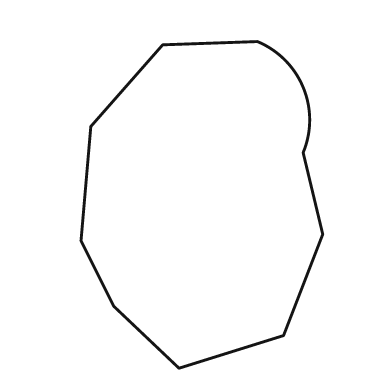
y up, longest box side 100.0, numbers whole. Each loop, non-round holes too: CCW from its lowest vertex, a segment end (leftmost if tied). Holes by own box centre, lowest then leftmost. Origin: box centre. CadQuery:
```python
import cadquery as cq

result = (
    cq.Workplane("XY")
    .moveTo(-7.0, -50.0)
    .lineTo(25.0, -40.0)
    .lineTo(37.0, -9.0)
    .lineTo(31.0, 16.0)
    .threePointArc((31.0, 36.0), (17.0, 50.0))
    .lineTo(-12.0, 49.0)
    .lineTo(-34.0, 24.0)
    .lineTo(-37.0, -11.0)
    .lineTo(-27.0, -31.0)
    .close()
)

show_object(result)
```